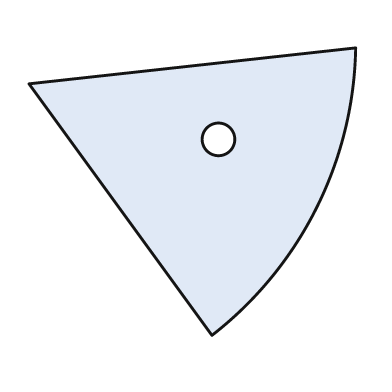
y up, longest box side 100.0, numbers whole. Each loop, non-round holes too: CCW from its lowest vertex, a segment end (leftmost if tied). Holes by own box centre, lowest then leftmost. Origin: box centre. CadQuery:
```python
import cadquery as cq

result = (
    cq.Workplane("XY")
    .moveTo(6.0, -44.0)
    .threePointArc((38.0, -5.0), (50.0, 44.0))
    .lineTo(-50.0, 33.0)
    .close()
    .moveTo(8.0, 16.0)
    .circle(5.0)
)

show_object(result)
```